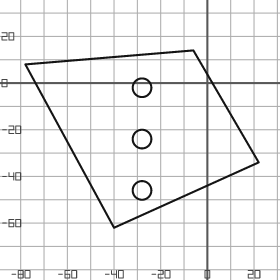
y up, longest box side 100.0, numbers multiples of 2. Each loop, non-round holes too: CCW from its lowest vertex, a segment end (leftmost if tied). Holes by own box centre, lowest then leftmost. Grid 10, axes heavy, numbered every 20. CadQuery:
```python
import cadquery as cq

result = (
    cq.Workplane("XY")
    .moveTo(-40.0, -62.0)
    .lineTo(22.0, -34.0)
    .lineTo(-6.0, 14.0)
    .lineTo(-78.0, 8.0)
    .close()
    .moveTo(-28.0, -46.0)
    .circle(4.0)
    .moveTo(-28.0, -24.0)
    .circle(4.0)
    .moveTo(-28.0, -2.0)
    .circle(4.0)
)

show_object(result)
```